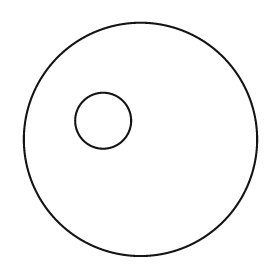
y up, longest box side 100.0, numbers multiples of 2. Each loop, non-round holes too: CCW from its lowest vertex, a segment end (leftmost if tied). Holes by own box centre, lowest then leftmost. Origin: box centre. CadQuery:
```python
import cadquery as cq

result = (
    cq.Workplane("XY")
    .moveTo(0.0, 0.0)
    .circle(50.0)
    .moveTo(-16.0, 8.0)
    .circle(12.0)
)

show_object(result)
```